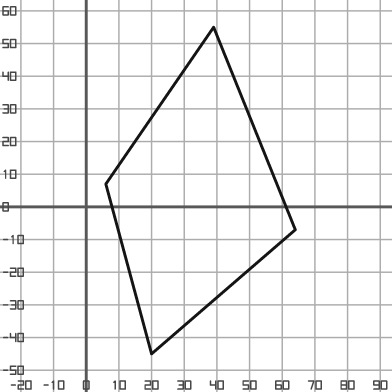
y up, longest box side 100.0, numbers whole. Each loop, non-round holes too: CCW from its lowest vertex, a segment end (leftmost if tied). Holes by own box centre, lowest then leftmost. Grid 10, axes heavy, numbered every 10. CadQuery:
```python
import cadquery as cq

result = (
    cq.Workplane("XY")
    .moveTo(20.0, -45.0)
    .lineTo(64.0, -7.0)
    .lineTo(39.0, 55.0)
    .lineTo(6.0, 7.0)
    .close()
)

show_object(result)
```